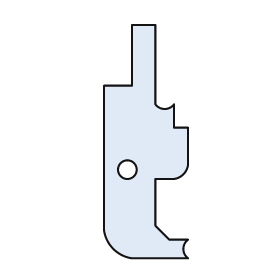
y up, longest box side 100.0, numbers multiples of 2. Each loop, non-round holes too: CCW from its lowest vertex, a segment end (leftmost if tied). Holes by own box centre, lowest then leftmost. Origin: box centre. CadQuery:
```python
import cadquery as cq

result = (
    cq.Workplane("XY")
    .moveTo(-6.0, -50.0)
    .lineTo(18.0, -50.0)
    .threePointArc((16.0, -46.0), (18.0, -42.0))
    .lineTo(10.0, -42.0)
    .lineTo(4.0, -36.0)
    .lineTo(4.0, -16.0)
    .lineTo(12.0, -16.0)
    .threePointArc((16.0, -14.0), (18.0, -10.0))
    .lineTo(18.0, 6.0)
    .lineTo(12.0, 6.0)
    .lineTo(12.0, 16.0)
    .threePointArc((8.0, 14.0), (4.0, 16.0))
    .lineTo(4.0, 50.0)
    .lineTo(-6.0, 50.0)
    .lineTo(-6.0, 24.0)
    .lineTo(-18.0, 24.0)
    .lineTo(-18.0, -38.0)
    .threePointArc((-14.0, -46.0), (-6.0, -50.0))
    .close()
    .moveTo(-8.0, -12.0)
    .circle(4.0)
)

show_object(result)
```